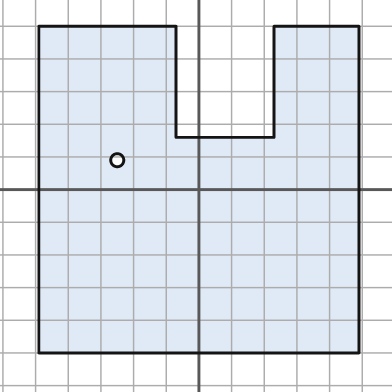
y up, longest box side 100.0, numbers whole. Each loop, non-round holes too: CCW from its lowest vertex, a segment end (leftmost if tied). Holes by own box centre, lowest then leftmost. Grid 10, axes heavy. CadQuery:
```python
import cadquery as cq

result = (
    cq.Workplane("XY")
    .moveTo(-49.0, -50.0)
    .lineTo(49.0, -50.0)
    .lineTo(49.0, 50.0)
    .lineTo(23.0, 50.0)
    .lineTo(23.0, 16.0)
    .lineTo(-7.0, 16.0)
    .lineTo(-7.0, 50.0)
    .lineTo(-49.0, 50.0)
    .close()
    .moveTo(-25.0, 9.0)
    .circle(2.0)
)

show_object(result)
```